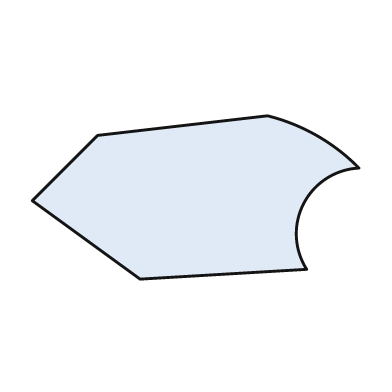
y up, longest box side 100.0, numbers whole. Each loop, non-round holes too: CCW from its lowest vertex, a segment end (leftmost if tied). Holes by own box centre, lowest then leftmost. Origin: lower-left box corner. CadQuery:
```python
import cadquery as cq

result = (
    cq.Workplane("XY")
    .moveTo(33.0, 0.0)
    .lineTo(84.0, 3.0)
    .threePointArc((83.0, 23.0), (100.0, 34.0))
    .threePointArc((87.0, 44.0), (72.0, 50.0))
    .lineTo(20.0, 44.0)
    .lineTo(0.0, 24.0)
    .close()
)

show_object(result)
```